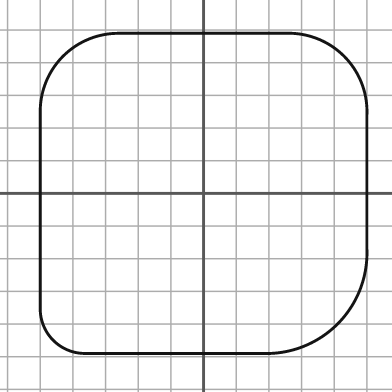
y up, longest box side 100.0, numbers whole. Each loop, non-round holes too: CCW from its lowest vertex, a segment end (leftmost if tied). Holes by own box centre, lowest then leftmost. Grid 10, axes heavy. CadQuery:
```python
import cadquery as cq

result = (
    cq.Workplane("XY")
    .moveTo(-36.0, -49.0)
    .lineTo(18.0, -49.0)
    .threePointArc((41.0, -40.0), (50.0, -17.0))
    .lineTo(50.0, 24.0)
    .threePointArc((43.0, 42.0), (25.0, 49.0))
    .lineTo(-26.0, 49.0)
    .threePointArc((-43.0, 42.0), (-50.0, 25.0))
    .lineTo(-50.0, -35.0)
    .threePointArc((-46.0, -45.0), (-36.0, -49.0))
    .close()
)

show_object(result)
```